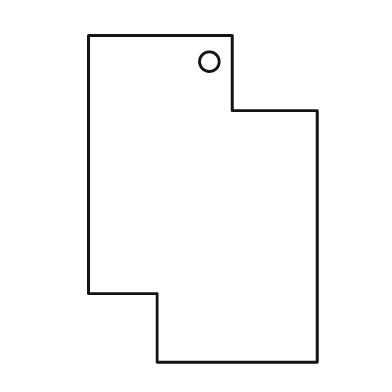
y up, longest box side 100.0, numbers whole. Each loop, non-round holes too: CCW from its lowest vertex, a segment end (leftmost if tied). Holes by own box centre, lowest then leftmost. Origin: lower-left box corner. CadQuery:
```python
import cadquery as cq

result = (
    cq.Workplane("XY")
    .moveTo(21.0, 0.0)
    .lineTo(70.0, 0.0)
    .lineTo(70.0, 77.0)
    .lineTo(44.0, 77.0)
    .lineTo(44.0, 100.0)
    .lineTo(0.0, 100.0)
    .lineTo(0.0, 21.0)
    .lineTo(21.0, 21.0)
    .close()
    .moveTo(37.0, 92.0)
    .circle(3.0)
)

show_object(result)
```